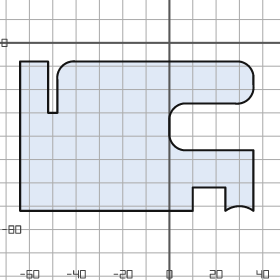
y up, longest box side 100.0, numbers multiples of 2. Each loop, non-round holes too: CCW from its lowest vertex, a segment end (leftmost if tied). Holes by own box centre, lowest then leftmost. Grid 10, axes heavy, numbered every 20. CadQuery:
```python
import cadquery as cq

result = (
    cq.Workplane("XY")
    .moveTo(-64.0, -72.0)
    .lineTo(10.0, -72.0)
    .lineTo(10.0, -62.0)
    .lineTo(24.0, -62.0)
    .lineTo(24.0, -72.0)
    .threePointArc((30.0, -70.0), (36.0, -72.0))
    .lineTo(36.0, -46.0)
    .lineTo(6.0, -46.0)
    .threePointArc((2.0, -44.0), (0.0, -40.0))
    .lineTo(0.0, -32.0)
    .threePointArc((2.0, -28.0), (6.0, -26.0))
    .lineTo(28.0, -26.0)
    .threePointArc((34.0, -24.0), (36.0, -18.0))
    .lineTo(36.0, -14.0)
    .threePointArc((34.0, -10.0), (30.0, -8.0))
    .lineTo(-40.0, -8.0)
    .threePointArc((-46.0, -10.0), (-48.0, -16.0))
    .lineTo(-48.0, -30.0)
    .lineTo(-52.0, -30.0)
    .lineTo(-52.0, -8.0)
    .lineTo(-64.0, -8.0)
    .close()
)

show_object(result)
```